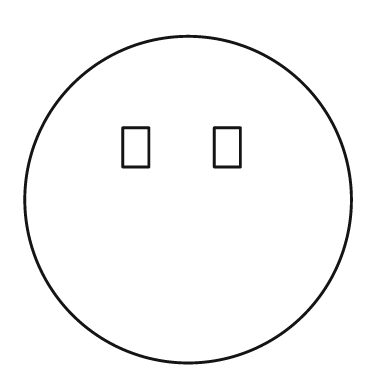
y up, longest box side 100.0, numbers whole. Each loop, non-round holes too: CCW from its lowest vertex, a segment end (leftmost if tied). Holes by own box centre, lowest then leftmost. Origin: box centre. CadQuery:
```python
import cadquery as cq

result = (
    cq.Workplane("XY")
    .moveTo(0.0, 0.0)
    .circle(50.0)
    .moveTo(-20.0, 10.0)
    .lineTo(-12.0, 10.0)
    .lineTo(-12.0, 22.0)
    .lineTo(-20.0, 22.0)
    .close()
    .moveTo(8.0, 10.0)
    .lineTo(16.0, 10.0)
    .lineTo(16.0, 22.0)
    .lineTo(8.0, 22.0)
    .close()
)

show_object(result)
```